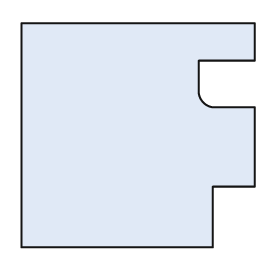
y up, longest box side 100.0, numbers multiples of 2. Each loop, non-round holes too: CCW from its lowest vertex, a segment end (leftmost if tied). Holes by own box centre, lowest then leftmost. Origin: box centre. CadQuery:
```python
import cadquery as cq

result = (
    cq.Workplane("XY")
    .moveTo(-50.0, -48.0)
    .lineTo(32.0, -48.0)
    .lineTo(32.0, -22.0)
    .lineTo(50.0, -22.0)
    .lineTo(50.0, 12.0)
    .lineTo(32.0, 12.0)
    .threePointArc((28.0, 14.0), (26.0, 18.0))
    .lineTo(26.0, 32.0)
    .lineTo(50.0, 32.0)
    .lineTo(50.0, 48.0)
    .lineTo(-50.0, 48.0)
    .close()
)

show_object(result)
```